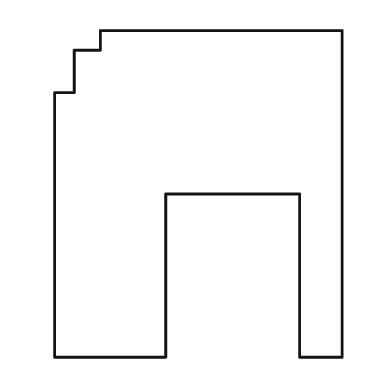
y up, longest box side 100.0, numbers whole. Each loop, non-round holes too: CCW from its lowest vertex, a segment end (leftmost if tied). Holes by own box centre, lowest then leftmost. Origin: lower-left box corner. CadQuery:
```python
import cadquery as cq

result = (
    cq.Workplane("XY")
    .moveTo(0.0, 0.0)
    .lineTo(34.0, 0.0)
    .lineTo(34.0, 50.0)
    .lineTo(75.0, 50.0)
    .lineTo(75.0, 0.0)
    .lineTo(88.0, 0.0)
    .lineTo(88.0, 100.0)
    .lineTo(14.0, 100.0)
    .lineTo(14.0, 94.0)
    .lineTo(6.0, 94.0)
    .lineTo(6.0, 81.0)
    .lineTo(0.0, 81.0)
    .close()
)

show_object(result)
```